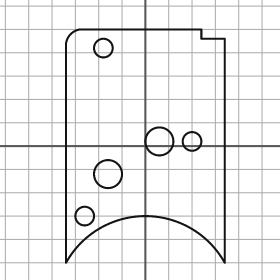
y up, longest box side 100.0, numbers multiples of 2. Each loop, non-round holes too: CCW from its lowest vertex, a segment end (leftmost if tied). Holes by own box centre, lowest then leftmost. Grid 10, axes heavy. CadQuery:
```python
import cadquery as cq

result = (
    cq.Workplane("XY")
    .moveTo(-34.0, -50.0)
    .threePointArc((0.0, -30.0), (34.0, -50.0))
    .lineTo(34.0, 46.0)
    .lineTo(24.0, 46.0)
    .lineTo(24.0, 50.0)
    .lineTo(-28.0, 50.0)
    .threePointArc((-32.0, 48.0), (-34.0, 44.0))
    .close()
    .moveTo(-26.0, -30.0)
    .circle(4.0)
    .moveTo(-16.0, -12.0)
    .circle(6.0)
    .moveTo(6.0, 2.0)
    .circle(6.0)
    .moveTo(20.0, 2.0)
    .circle(4.0)
    .moveTo(-18.0, 42.0)
    .circle(4.0)
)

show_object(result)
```